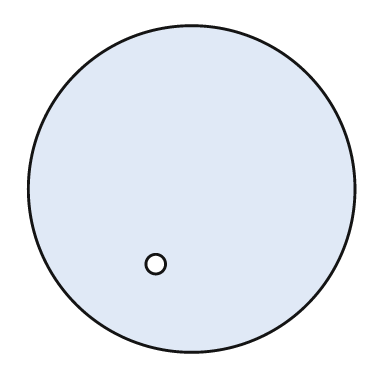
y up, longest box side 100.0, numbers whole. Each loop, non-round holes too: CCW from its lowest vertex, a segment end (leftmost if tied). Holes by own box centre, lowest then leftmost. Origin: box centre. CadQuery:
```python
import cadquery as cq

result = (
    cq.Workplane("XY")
    .moveTo(0.0, 0.0)
    .circle(50.0)
    .moveTo(-11.0, -23.0)
    .circle(3.0)
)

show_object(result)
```